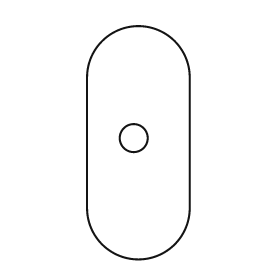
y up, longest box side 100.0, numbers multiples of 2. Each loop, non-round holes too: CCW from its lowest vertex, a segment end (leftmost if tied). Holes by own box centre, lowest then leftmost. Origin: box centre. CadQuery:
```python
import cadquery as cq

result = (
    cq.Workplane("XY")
    .moveTo(-22.0, -28.0)
    .threePointArc((0.0, -50.0), (22.0, -28.0))
    .lineTo(22.0, 28.0)
    .threePointArc((0.0, 50.0), (-22.0, 28.0))
    .close()
    .moveTo(-2.0, 2.0)
    .circle(6.0)
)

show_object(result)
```